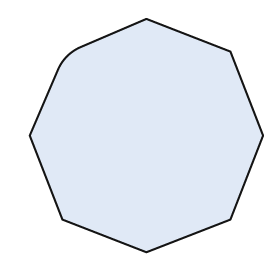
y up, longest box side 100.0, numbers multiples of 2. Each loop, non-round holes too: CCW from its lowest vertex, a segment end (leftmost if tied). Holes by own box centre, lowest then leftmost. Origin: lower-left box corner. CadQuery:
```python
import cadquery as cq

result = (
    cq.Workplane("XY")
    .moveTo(50.0, 0.0)
    .lineTo(86.0, 14.0)
    .lineTo(100.0, 50.0)
    .lineTo(86.0, 86.0)
    .lineTo(50.0, 100.0)
    .lineTo(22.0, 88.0)
    .threePointArc((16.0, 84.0), (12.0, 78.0))
    .lineTo(0.0, 50.0)
    .lineTo(14.0, 14.0)
    .close()
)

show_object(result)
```